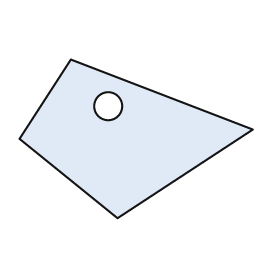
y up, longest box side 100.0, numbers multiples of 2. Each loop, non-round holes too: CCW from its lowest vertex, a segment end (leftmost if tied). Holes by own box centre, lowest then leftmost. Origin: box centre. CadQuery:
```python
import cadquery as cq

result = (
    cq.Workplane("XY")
    .moveTo(-8.0, -34.0)
    .lineTo(50.0, 4.0)
    .lineTo(-28.0, 34.0)
    .lineTo(-50.0, 0.0)
    .close()
    .moveTo(-12.0, 14.0)
    .circle(6.0)
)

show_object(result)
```